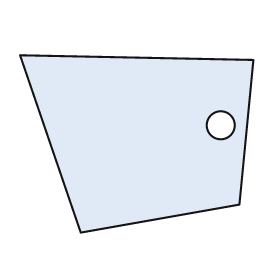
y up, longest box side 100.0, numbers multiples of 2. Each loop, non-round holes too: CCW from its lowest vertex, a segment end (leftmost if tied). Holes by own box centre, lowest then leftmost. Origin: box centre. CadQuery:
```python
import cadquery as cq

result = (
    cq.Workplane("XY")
    .moveTo(-24.0, -38.0)
    .lineTo(44.0, -26.0)
    .lineTo(50.0, 36.0)
    .lineTo(-50.0, 38.0)
    .close()
    .moveTo(36.0, 8.0)
    .circle(6.0)
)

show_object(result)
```